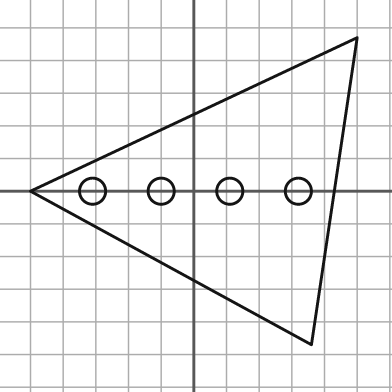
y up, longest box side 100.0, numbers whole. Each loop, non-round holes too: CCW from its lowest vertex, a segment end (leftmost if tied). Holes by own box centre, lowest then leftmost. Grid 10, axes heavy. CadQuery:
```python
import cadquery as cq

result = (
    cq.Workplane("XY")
    .moveTo(36.0, -47.0)
    .lineTo(50.0, 47.0)
    .lineTo(-50.0, 0.0)
    .close()
    .moveTo(-31.0, 0.0)
    .circle(4.0)
    .moveTo(-10.0, 0.0)
    .circle(4.0)
    .moveTo(11.0, 0.0)
    .circle(4.0)
    .moveTo(32.0, 0.0)
    .circle(4.0)
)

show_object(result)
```